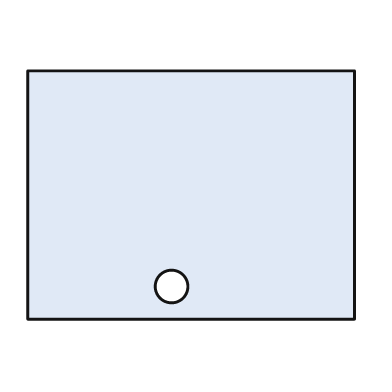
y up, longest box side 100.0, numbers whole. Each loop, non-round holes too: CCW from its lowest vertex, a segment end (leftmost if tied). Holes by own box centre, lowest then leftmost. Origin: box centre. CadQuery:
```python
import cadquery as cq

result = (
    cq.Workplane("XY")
    .moveTo(-50.0, -38.0)
    .lineTo(50.0, -38.0)
    .lineTo(50.0, 38.0)
    .lineTo(-50.0, 38.0)
    .close()
    .moveTo(-6.0, -28.0)
    .circle(5.0)
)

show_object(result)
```